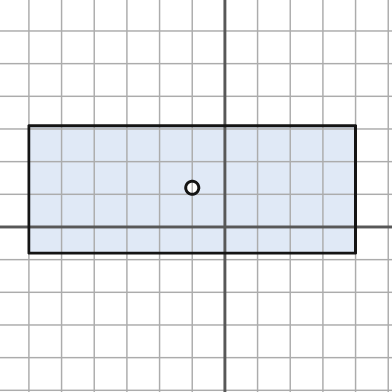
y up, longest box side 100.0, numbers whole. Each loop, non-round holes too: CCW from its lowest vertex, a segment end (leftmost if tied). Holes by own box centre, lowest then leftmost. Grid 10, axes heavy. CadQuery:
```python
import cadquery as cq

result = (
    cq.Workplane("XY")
    .moveTo(-60.0, -8.0)
    .lineTo(40.0, -8.0)
    .lineTo(40.0, 31.0)
    .lineTo(-60.0, 31.0)
    .close()
    .moveTo(-10.0, 12.0)
    .circle(2.0)
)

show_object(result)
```